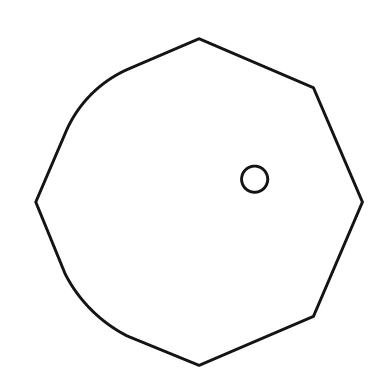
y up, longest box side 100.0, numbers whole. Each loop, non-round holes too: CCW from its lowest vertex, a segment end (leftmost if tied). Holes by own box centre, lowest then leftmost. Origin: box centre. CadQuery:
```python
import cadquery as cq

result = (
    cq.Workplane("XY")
    .moveTo(0.0, -50.0)
    .lineTo(35.0, -35.0)
    .lineTo(50.0, 0.0)
    .lineTo(35.0, 35.0)
    .lineTo(0.0, 50.0)
    .lineTo(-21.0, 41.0)
    .threePointArc((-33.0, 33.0), (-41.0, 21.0))
    .lineTo(-50.0, 0.0)
    .lineTo(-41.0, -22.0)
    .threePointArc((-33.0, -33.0), (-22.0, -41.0))
    .close()
    .moveTo(17.0, 7.0)
    .circle(4.0)
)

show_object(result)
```